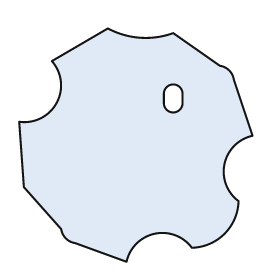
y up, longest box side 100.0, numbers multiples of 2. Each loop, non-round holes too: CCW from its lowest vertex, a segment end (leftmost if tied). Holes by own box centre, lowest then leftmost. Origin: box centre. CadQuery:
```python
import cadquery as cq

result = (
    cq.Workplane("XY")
    .moveTo(-4.0, -50.0)
    .threePointArc((8.0, -38.0), (24.0, -44.0))
    .threePointArc((38.0, -38.0), (44.0, -24.0))
    .threePointArc((38.0, -8.0), (50.0, 4.0))
    .lineTo(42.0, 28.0)
    .threePointArc((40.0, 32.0), (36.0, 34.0))
    .lineTo(16.0, 48.0)
    .threePointArc((2.0, 46.0), (-12.0, 50.0))
    .lineTo(-36.0, 36.0)
    .threePointArc((-34.0, 18.0), (-50.0, 10.0))
    .lineTo(-48.0, -18.0)
    .lineTo(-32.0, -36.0)
    .threePointArc((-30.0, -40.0), (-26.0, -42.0))
    .close()
    .moveTo(12.0, 18.0)
    .threePointArc((16.0, 14.0), (20.0, 18.0))
    .lineTo(20.0, 22.0)
    .threePointArc((16.0, 26.0), (12.0, 22.0))
    .close()
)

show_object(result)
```